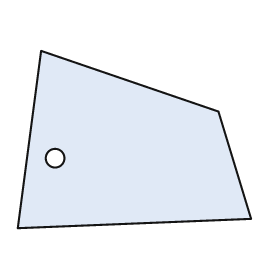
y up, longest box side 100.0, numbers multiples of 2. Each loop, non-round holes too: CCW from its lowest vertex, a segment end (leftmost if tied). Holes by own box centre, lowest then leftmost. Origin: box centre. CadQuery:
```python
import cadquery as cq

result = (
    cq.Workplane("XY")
    .moveTo(-50.0, -38.0)
    .lineTo(50.0, -34.0)
    .lineTo(36.0, 12.0)
    .lineTo(-40.0, 38.0)
    .close()
    .moveTo(-34.0, -8.0)
    .circle(4.0)
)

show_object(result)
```